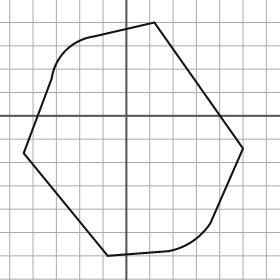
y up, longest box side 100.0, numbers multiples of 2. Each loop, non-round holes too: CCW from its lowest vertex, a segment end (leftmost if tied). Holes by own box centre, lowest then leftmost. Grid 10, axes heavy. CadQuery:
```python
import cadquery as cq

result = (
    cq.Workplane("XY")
    .moveTo(-8.0, -60.0)
    .lineTo(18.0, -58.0)
    .threePointArc((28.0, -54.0), (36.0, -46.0))
    .lineTo(50.0, -14.0)
    .lineTo(12.0, 40.0)
    .lineTo(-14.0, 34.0)
    .threePointArc((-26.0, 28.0), (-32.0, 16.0))
    .lineTo(-44.0, -16.0)
    .close()
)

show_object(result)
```